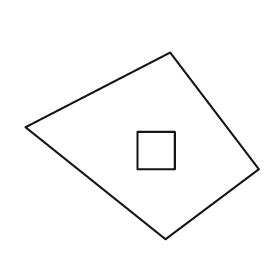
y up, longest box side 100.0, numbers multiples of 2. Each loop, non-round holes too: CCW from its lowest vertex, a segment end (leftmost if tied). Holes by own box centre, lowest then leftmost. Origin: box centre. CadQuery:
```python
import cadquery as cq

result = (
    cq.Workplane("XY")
    .moveTo(10.0, -40.0)
    .lineTo(50.0, -10.0)
    .lineTo(12.0, 40.0)
    .lineTo(-50.0, 8.0)
    .close()
    .moveTo(-2.0, -10.0)
    .lineTo(14.0, -10.0)
    .lineTo(14.0, 6.0)
    .lineTo(-2.0, 6.0)
    .close()
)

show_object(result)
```